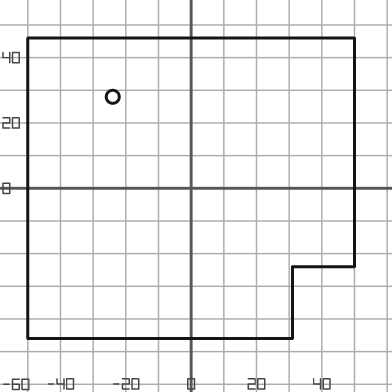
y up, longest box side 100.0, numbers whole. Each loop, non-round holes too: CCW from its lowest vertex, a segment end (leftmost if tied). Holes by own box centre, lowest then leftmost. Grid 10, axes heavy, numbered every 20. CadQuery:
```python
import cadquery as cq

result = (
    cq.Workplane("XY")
    .moveTo(-50.0, -46.0)
    .lineTo(31.0, -46.0)
    .lineTo(31.0, -24.0)
    .lineTo(50.0, -24.0)
    .lineTo(50.0, 46.0)
    .lineTo(-50.0, 46.0)
    .close()
    .moveTo(-24.0, 28.0)
    .circle(2.0)
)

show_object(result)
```